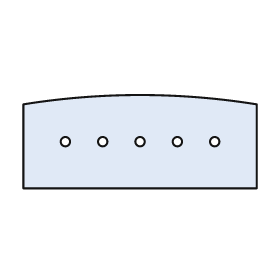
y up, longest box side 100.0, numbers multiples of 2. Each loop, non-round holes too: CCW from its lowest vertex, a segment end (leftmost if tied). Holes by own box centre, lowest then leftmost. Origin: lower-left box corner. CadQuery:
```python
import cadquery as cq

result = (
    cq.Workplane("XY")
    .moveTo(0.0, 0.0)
    .lineTo(100.0, 0.0)
    .lineTo(100.0, 36.0)
    .threePointArc((50.0, 40.0), (0.0, 36.0))
    .close()
    .moveTo(18.0, 20.0)
    .circle(2.0)
    .moveTo(34.0, 20.0)
    .circle(2.0)
    .moveTo(50.0, 20.0)
    .circle(2.0)
    .moveTo(66.0, 20.0)
    .circle(2.0)
    .moveTo(82.0, 20.0)
    .circle(2.0)
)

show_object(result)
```